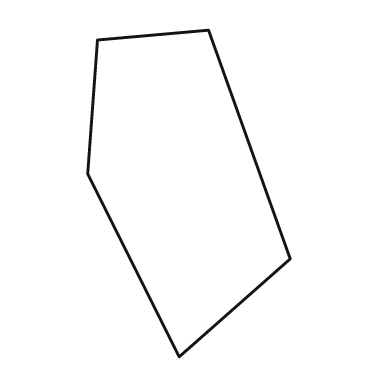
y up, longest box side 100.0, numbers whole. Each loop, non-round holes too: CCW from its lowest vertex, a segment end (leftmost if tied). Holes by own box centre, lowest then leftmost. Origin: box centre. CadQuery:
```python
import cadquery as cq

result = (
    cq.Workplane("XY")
    .moveTo(-3.0, -50.0)
    .lineTo(31.0, -20.0)
    .lineTo(6.0, 50.0)
    .lineTo(-28.0, 47.0)
    .lineTo(-31.0, 6.0)
    .close()
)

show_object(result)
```